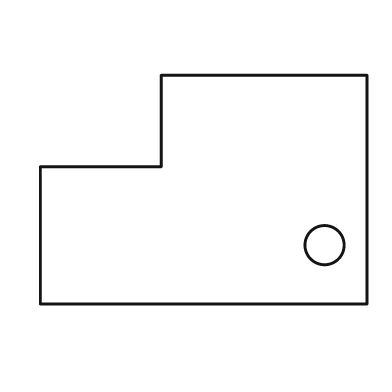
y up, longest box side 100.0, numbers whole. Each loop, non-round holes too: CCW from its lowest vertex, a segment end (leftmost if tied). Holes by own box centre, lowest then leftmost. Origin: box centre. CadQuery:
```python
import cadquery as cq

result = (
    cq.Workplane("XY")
    .moveTo(-50.0, -35.0)
    .lineTo(50.0, -35.0)
    .lineTo(50.0, 35.0)
    .lineTo(-13.0, 35.0)
    .lineTo(-13.0, 7.0)
    .lineTo(-50.0, 7.0)
    .close()
    .moveTo(37.0, -17.0)
    .circle(6.0)
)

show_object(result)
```